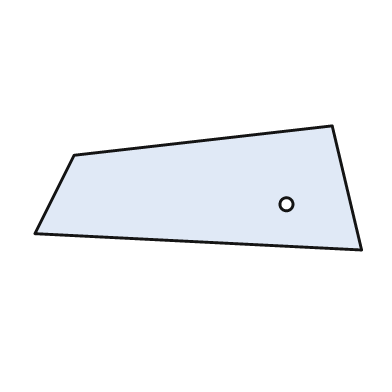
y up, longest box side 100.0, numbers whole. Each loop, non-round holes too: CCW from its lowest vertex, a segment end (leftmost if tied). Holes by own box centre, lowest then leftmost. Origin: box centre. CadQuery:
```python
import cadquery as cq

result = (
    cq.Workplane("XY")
    .moveTo(50.0, -19.0)
    .lineTo(41.0, 19.0)
    .lineTo(-38.0, 10.0)
    .lineTo(-50.0, -14.0)
    .close()
    .moveTo(27.0, -5.0)
    .circle(2.0)
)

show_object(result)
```